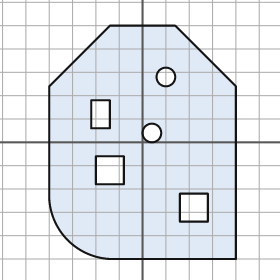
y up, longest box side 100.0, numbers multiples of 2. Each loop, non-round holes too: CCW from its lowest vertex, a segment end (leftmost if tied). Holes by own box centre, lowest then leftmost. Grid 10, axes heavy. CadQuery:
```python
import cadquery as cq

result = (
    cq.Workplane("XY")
    .moveTo(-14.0, -50.0)
    .lineTo(40.0, -50.0)
    .lineTo(40.0, 24.0)
    .lineTo(14.0, 50.0)
    .lineTo(-14.0, 50.0)
    .lineTo(-40.0, 24.0)
    .lineTo(-40.0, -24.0)
    .threePointArc((-32.0, -42.0), (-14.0, -50.0))
    .close()
    .moveTo(16.0, -34.0)
    .lineTo(28.0, -34.0)
    .lineTo(28.0, -22.0)
    .lineTo(16.0, -22.0)
    .close()
    .moveTo(-20.0, -18.0)
    .lineTo(-8.0, -18.0)
    .lineTo(-8.0, -6.0)
    .lineTo(-20.0, -6.0)
    .close()
    .moveTo(4.0, 4.0)
    .circle(4.0)
    .moveTo(-22.0, 6.0)
    .lineTo(-14.0, 6.0)
    .lineTo(-14.0, 18.0)
    .lineTo(-22.0, 18.0)
    .close()
    .moveTo(10.0, 28.0)
    .circle(4.0)
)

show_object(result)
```